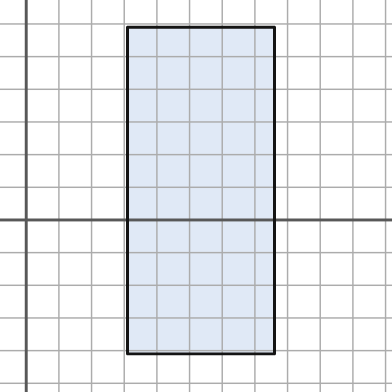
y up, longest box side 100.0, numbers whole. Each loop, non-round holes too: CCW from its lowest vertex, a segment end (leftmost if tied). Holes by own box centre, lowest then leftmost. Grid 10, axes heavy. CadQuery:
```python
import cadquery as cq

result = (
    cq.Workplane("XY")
    .moveTo(31.0, -41.0)
    .lineTo(76.0, -41.0)
    .lineTo(76.0, 59.0)
    .lineTo(31.0, 59.0)
    .close()
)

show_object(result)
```